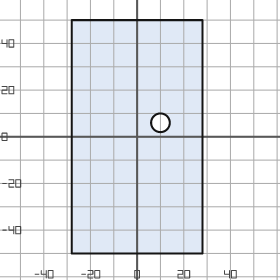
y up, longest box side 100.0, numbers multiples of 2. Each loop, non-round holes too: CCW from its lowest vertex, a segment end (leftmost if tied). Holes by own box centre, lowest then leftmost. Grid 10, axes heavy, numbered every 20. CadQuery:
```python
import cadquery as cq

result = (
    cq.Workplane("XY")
    .moveTo(-28.0, -50.0)
    .lineTo(28.0, -50.0)
    .lineTo(28.0, 50.0)
    .lineTo(-28.0, 50.0)
    .close()
    .moveTo(10.0, 6.0)
    .circle(4.0)
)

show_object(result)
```